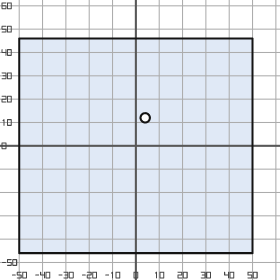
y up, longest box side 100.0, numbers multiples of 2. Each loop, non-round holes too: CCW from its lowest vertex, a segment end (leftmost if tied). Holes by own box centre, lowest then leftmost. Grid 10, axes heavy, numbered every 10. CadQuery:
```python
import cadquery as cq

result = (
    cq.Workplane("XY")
    .moveTo(-50.0, -46.0)
    .lineTo(50.0, -46.0)
    .lineTo(50.0, 46.0)
    .lineTo(-50.0, 46.0)
    .close()
    .moveTo(4.0, 12.0)
    .circle(2.0)
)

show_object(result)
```